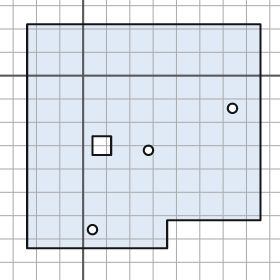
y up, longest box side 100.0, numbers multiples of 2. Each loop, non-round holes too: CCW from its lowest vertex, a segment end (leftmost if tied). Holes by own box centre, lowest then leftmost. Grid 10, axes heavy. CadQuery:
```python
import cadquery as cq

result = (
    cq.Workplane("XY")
    .moveTo(-24.0, -74.0)
    .lineTo(36.0, -74.0)
    .lineTo(36.0, -62.0)
    .lineTo(76.0, -62.0)
    .lineTo(76.0, 22.0)
    .lineTo(-24.0, 22.0)
    .close()
    .moveTo(4.0, -66.0)
    .circle(2.0)
    .moveTo(28.0, -32.0)
    .circle(2.0)
    .moveTo(4.0, -34.0)
    .lineTo(12.0, -34.0)
    .lineTo(12.0, -26.0)
    .lineTo(4.0, -26.0)
    .close()
    .moveTo(64.0, -14.0)
    .circle(2.0)
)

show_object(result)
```